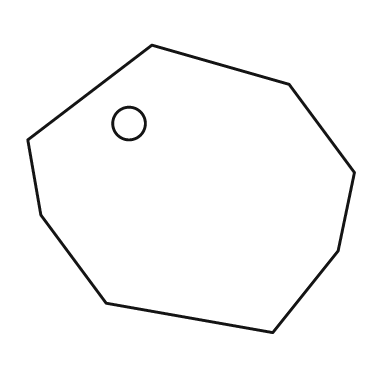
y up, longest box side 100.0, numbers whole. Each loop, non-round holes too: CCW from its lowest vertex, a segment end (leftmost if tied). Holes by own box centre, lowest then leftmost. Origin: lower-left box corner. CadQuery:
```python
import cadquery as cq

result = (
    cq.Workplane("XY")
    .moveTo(75.0, 0.0)
    .lineTo(95.0, 25.0)
    .lineTo(100.0, 49.0)
    .lineTo(80.0, 76.0)
    .lineTo(38.0, 88.0)
    .lineTo(0.0, 59.0)
    .lineTo(4.0, 36.0)
    .lineTo(24.0, 9.0)
    .close()
    .moveTo(31.0, 64.0)
    .circle(5.0)
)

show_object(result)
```